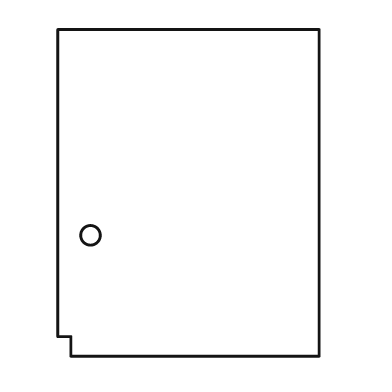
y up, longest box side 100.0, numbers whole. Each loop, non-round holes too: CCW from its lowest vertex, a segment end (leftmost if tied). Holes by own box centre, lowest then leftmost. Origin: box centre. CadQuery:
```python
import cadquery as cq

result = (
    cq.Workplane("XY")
    .moveTo(-36.0, -50.0)
    .lineTo(40.0, -50.0)
    .lineTo(40.0, 50.0)
    .lineTo(-40.0, 50.0)
    .lineTo(-40.0, -44.0)
    .lineTo(-36.0, -44.0)
    .close()
    .moveTo(-30.0, -13.0)
    .circle(3.0)
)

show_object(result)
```